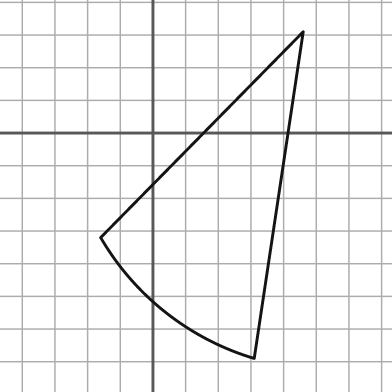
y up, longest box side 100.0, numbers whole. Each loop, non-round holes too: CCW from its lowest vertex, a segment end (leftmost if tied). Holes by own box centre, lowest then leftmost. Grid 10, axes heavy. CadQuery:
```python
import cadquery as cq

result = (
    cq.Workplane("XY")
    .moveTo(31.0, -69.0)
    .lineTo(46.0, 31.0)
    .lineTo(-16.0, -32.0)
    .threePointArc((4.0, -55.0), (31.0, -69.0))
    .close()
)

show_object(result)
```